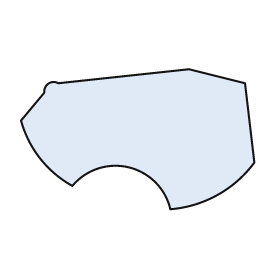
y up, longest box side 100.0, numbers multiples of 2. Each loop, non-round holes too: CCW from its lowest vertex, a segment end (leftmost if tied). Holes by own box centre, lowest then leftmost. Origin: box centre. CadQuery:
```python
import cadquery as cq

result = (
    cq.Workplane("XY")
    .moveTo(14.0, -30.0)
    .threePointArc((34.0, -24.0), (50.0, -10.0))
    .lineTo(46.0, 24.0)
    .lineTo(22.0, 30.0)
    .lineTo(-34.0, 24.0)
    .threePointArc((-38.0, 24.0), (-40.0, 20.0))
    .lineTo(-50.0, 8.0)
    .threePointArc((-42.0, -8.0), (-28.0, -20.0))
    .threePointArc((-4.0, -12.0), (14.0, -30.0))
    .close()
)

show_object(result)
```